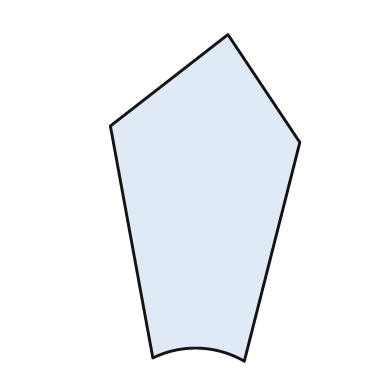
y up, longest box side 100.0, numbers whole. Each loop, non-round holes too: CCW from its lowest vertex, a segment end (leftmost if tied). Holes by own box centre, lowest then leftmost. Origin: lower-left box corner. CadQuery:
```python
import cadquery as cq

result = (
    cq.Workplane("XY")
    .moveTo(41.0, 0.0)
    .lineTo(58.0, 67.0)
    .lineTo(36.0, 100.0)
    .lineTo(0.0, 72.0)
    .lineTo(13.0, 1.0)
    .threePointArc((27.0, 4.0), (41.0, 0.0))
    .close()
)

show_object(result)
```